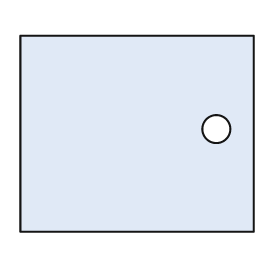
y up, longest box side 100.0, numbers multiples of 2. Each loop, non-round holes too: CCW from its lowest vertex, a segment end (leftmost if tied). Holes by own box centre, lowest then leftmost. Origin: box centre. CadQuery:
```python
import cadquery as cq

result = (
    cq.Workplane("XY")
    .moveTo(-50.0, -42.0)
    .lineTo(50.0, -42.0)
    .lineTo(50.0, 42.0)
    .lineTo(-50.0, 42.0)
    .close()
    .moveTo(34.0, 2.0)
    .circle(6.0)
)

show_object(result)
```